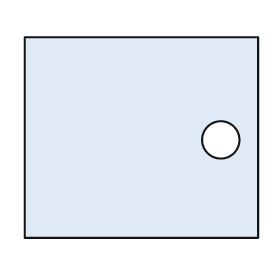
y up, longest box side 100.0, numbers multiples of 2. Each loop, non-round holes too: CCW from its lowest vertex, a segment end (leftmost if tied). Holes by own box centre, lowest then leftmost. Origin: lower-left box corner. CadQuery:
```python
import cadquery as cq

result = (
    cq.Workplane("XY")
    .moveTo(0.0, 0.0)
    .lineTo(100.0, 0.0)
    .lineTo(100.0, 86.0)
    .lineTo(0.0, 86.0)
    .close()
    .moveTo(84.0, 42.0)
    .circle(8.0)
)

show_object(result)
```